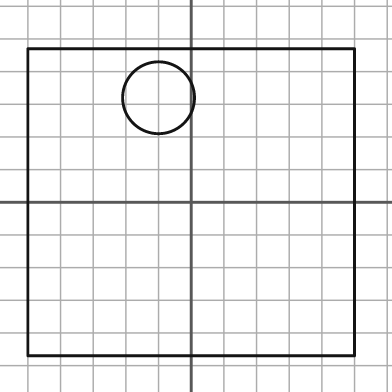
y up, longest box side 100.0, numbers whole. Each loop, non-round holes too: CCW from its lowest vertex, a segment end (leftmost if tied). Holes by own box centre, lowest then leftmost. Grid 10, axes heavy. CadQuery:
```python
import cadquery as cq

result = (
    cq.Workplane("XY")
    .moveTo(-50.0, -47.0)
    .lineTo(50.0, -47.0)
    .lineTo(50.0, 47.0)
    .lineTo(-50.0, 47.0)
    .close()
    .moveTo(-10.0, 32.0)
    .circle(11.0)
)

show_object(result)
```